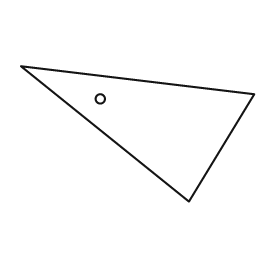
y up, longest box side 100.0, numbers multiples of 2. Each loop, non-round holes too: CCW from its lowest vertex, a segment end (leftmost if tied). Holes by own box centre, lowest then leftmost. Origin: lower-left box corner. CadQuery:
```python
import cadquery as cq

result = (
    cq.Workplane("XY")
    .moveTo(72.0, 0.0)
    .lineTo(100.0, 46.0)
    .lineTo(0.0, 58.0)
    .close()
    .moveTo(34.0, 44.0)
    .circle(2.0)
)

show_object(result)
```